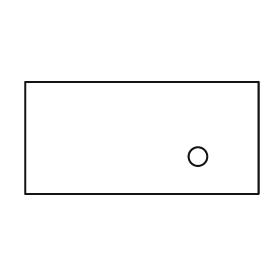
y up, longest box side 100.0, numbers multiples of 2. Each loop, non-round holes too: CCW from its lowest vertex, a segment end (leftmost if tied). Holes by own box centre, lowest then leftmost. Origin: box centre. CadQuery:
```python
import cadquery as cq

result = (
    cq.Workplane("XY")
    .moveTo(-50.0, -24.0)
    .lineTo(50.0, -24.0)
    .lineTo(50.0, 24.0)
    .lineTo(-50.0, 24.0)
    .close()
    .moveTo(24.0, -8.0)
    .circle(4.0)
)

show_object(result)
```